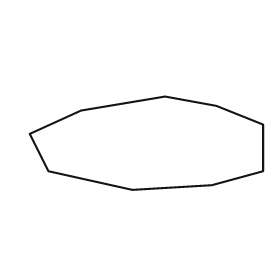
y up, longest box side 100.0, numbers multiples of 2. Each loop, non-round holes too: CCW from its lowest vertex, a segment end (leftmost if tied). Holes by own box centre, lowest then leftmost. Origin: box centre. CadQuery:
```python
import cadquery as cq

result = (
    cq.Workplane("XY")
    .moveTo(-6.0, -20.0)
    .lineTo(28.0, -18.0)
    .lineTo(50.0, -12.0)
    .lineTo(50.0, 8.0)
    .lineTo(30.0, 16.0)
    .lineTo(8.0, 20.0)
    .lineTo(-28.0, 14.0)
    .lineTo(-50.0, 4.0)
    .lineTo(-42.0, -12.0)
    .close()
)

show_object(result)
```